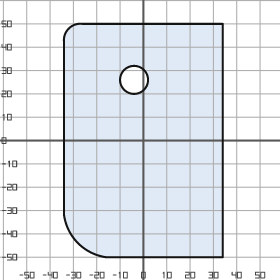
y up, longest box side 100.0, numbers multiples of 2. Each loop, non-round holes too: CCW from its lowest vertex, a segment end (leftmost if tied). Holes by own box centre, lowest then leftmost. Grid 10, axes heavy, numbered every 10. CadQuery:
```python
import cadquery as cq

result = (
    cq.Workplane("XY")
    .moveTo(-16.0, -50.0)
    .lineTo(34.0, -50.0)
    .lineTo(34.0, 50.0)
    .lineTo(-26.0, 50.0)
    .threePointArc((-32.0, 48.0), (-34.0, 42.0))
    .lineTo(-34.0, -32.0)
    .threePointArc((-28.0, -44.0), (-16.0, -50.0))
    .close()
    .moveTo(-4.0, 26.0)
    .circle(6.0)
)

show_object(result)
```